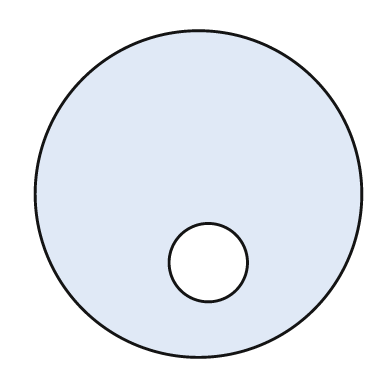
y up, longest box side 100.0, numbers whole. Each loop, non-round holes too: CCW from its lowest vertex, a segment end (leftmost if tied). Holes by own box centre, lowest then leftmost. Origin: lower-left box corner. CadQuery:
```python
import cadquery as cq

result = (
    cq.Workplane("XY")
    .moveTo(50.0, 50.0)
    .circle(50.0)
    .moveTo(53.0, 29.0)
    .circle(12.0)
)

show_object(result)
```